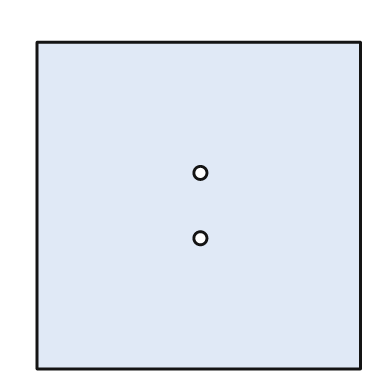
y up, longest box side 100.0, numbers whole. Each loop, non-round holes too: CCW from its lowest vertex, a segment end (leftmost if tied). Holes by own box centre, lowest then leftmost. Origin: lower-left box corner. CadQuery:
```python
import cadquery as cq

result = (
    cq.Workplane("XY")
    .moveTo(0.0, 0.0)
    .lineTo(99.0, 0.0)
    .lineTo(99.0, 100.0)
    .lineTo(0.0, 100.0)
    .close()
    .moveTo(50.0, 40.0)
    .circle(2.0)
    .moveTo(50.0, 60.0)
    .circle(2.0)
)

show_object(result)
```